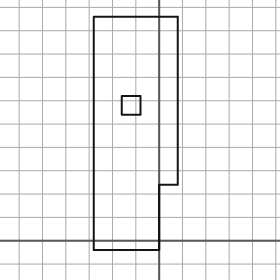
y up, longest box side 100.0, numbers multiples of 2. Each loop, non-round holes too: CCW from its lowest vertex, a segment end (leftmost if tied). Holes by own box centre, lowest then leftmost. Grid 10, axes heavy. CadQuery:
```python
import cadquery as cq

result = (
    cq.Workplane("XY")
    .moveTo(-28.0, -4.0)
    .lineTo(0.0, -4.0)
    .lineTo(0.0, 24.0)
    .lineTo(8.0, 24.0)
    .lineTo(8.0, 96.0)
    .lineTo(-28.0, 96.0)
    .close()
    .moveTo(-16.0, 54.0)
    .lineTo(-8.0, 54.0)
    .lineTo(-8.0, 62.0)
    .lineTo(-16.0, 62.0)
    .close()
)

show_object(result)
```